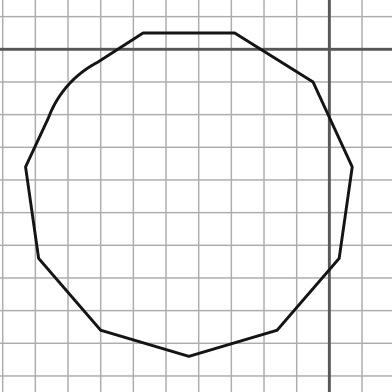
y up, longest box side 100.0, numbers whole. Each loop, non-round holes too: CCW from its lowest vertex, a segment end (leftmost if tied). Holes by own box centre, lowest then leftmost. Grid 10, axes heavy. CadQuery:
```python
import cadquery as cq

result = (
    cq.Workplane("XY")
    .moveTo(-43.0, -94.0)
    .lineTo(-16.0, -86.0)
    .lineTo(3.0, -64.0)
    .lineTo(7.0, -36.0)
    .lineTo(-5.0, -10.0)
    .lineTo(-29.0, 5.0)
    .lineTo(-57.0, 5.0)
    .lineTo(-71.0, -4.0)
    .threePointArc((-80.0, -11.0), (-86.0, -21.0))
    .lineTo(-93.0, -36.0)
    .lineTo(-89.0, -64.0)
    .lineTo(-70.0, -86.0)
    .close()
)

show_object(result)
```